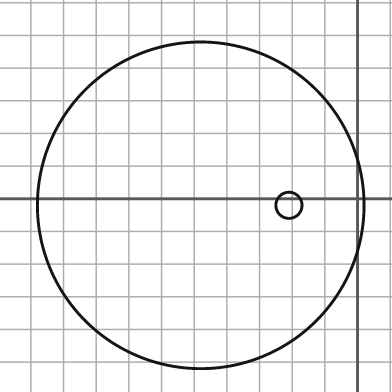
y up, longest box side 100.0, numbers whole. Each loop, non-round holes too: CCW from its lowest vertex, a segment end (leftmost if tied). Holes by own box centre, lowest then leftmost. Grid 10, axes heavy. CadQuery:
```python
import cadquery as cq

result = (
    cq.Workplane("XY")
    .moveTo(-48.0, -2.0)
    .circle(50.0)
    .moveTo(-21.0, -2.0)
    .circle(4.0)
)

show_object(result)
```